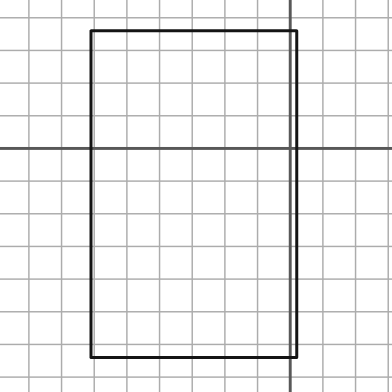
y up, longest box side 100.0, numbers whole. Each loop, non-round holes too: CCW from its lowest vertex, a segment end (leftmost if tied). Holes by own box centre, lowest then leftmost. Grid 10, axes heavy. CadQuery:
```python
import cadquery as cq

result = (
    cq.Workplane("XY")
    .moveTo(-61.0, -64.0)
    .lineTo(2.0, -64.0)
    .lineTo(2.0, 36.0)
    .lineTo(-61.0, 36.0)
    .close()
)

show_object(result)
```